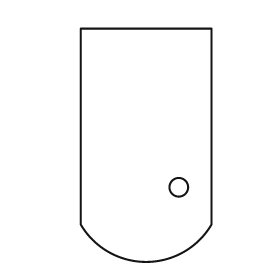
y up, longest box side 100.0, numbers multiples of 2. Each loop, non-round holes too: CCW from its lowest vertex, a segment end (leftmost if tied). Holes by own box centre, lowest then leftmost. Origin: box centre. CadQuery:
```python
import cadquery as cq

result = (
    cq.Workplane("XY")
    .moveTo(-28.0, -34.0)
    .threePointArc((0.0, -50.0), (28.0, -34.0))
    .lineTo(28.0, 50.0)
    .lineTo(-28.0, 50.0)
    .close()
    .moveTo(14.0, -18.0)
    .circle(4.0)
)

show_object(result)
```